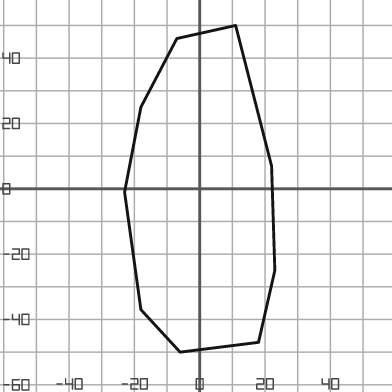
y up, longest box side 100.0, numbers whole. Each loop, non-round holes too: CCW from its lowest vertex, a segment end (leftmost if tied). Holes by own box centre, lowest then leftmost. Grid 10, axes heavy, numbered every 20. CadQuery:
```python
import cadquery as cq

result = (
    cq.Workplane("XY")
    .moveTo(-6.0, -50.0)
    .lineTo(18.0, -47.0)
    .lineTo(23.0, -25.0)
    .lineTo(22.0, 7.0)
    .lineTo(11.0, 50.0)
    .lineTo(-7.0, 46.0)
    .lineTo(-18.0, 25.0)
    .lineTo(-23.0, -1.0)
    .lineTo(-18.0, -37.0)
    .close()
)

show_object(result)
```